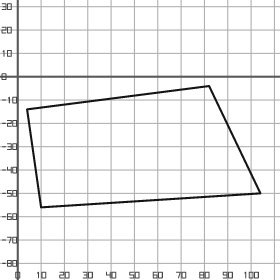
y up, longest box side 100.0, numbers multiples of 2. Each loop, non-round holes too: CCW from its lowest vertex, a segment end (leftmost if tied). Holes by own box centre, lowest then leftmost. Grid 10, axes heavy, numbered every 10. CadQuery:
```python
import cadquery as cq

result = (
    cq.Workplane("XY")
    .moveTo(10.0, -56.0)
    .lineTo(104.0, -50.0)
    .lineTo(82.0, -4.0)
    .lineTo(4.0, -14.0)
    .close()
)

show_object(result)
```